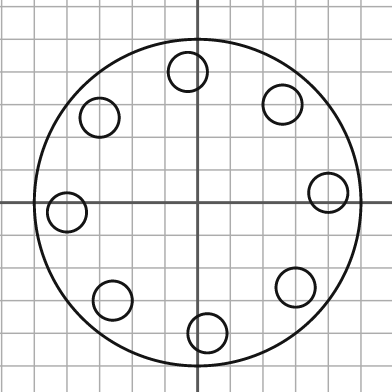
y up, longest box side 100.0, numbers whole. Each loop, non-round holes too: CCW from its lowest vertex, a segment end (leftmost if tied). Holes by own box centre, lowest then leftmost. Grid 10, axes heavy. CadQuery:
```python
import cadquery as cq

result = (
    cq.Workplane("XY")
    .moveTo(0.0, 0.0)
    .circle(50.0)
    .moveTo(3.0, -40.0)
    .circle(6.0)
    .moveTo(-26.0, -30.0)
    .circle(6.0)
    .moveTo(30.0, -26.0)
    .circle(6.0)
    .moveTo(-40.0, -3.0)
    .circle(6.0)
    .moveTo(40.0, 3.0)
    .circle(6.0)
    .moveTo(-30.0, 26.0)
    .circle(6.0)
    .moveTo(26.0, 30.0)
    .circle(6.0)
    .moveTo(-3.0, 40.0)
    .circle(6.0)
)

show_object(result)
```